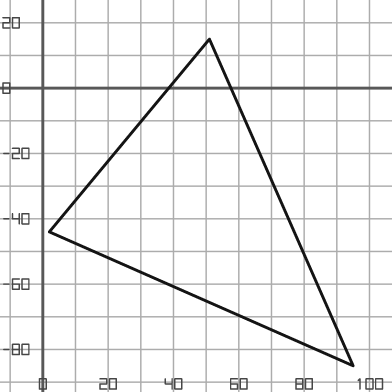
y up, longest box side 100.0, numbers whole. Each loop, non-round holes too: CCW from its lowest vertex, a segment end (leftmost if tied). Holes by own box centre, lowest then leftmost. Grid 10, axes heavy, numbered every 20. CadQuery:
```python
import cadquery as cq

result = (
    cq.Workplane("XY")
    .moveTo(95.0, -85.0)
    .lineTo(51.0, 15.0)
    .lineTo(2.0, -44.0)
    .close()
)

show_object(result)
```